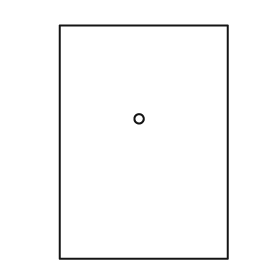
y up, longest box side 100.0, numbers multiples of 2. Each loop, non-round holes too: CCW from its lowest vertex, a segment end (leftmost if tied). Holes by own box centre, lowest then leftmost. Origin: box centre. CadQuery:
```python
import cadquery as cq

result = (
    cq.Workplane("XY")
    .moveTo(-36.0, -50.0)
    .lineTo(36.0, -50.0)
    .lineTo(36.0, 50.0)
    .lineTo(-36.0, 50.0)
    .close()
    .moveTo(-2.0, 10.0)
    .circle(2.0)
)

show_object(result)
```